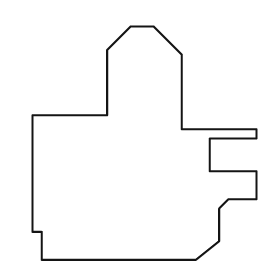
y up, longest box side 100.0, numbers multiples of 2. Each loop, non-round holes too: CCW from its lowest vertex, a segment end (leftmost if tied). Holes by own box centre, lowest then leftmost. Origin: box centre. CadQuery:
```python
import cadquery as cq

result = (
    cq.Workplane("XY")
    .moveTo(-44.0, -50.0)
    .lineTo(22.0, -50.0)
    .lineTo(32.0, -42.0)
    .lineTo(32.0, -28.0)
    .lineTo(36.0, -24.0)
    .lineTo(48.0, -24.0)
    .lineTo(48.0, -12.0)
    .lineTo(28.0, -12.0)
    .lineTo(28.0, 2.0)
    .lineTo(48.0, 2.0)
    .lineTo(48.0, 6.0)
    .lineTo(16.0, 6.0)
    .lineTo(16.0, 38.0)
    .lineTo(4.0, 50.0)
    .lineTo(-6.0, 50.0)
    .lineTo(-16.0, 40.0)
    .lineTo(-16.0, 12.0)
    .lineTo(-48.0, 12.0)
    .lineTo(-48.0, -38.0)
    .lineTo(-44.0, -38.0)
    .close()
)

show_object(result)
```